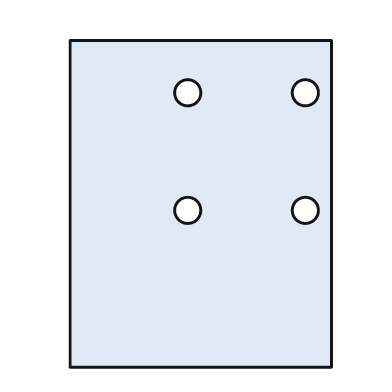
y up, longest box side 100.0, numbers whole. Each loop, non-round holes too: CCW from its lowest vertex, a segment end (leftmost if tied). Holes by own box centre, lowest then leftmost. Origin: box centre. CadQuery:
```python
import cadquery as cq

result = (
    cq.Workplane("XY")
    .moveTo(-40.0, -50.0)
    .lineTo(40.0, -50.0)
    .lineTo(40.0, 50.0)
    .lineTo(-40.0, 50.0)
    .close()
    .moveTo(-4.0, -2.0)
    .circle(4.0)
    .moveTo(32.0, -2.0)
    .circle(4.0)
    .moveTo(-4.0, 34.0)
    .circle(4.0)
    .moveTo(32.0, 34.0)
    .circle(4.0)
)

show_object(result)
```